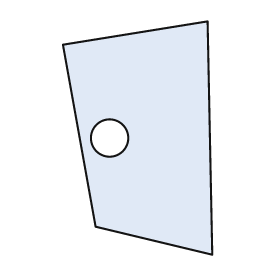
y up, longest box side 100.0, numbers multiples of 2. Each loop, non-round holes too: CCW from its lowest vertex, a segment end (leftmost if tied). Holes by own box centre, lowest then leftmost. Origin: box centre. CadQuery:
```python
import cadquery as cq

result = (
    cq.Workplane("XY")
    .moveTo(32.0, -50.0)
    .lineTo(30.0, 50.0)
    .lineTo(-32.0, 40.0)
    .lineTo(-18.0, -38.0)
    .close()
    .moveTo(-12.0, 0.0)
    .circle(8.0)
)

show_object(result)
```